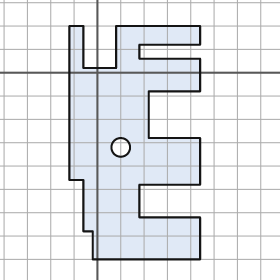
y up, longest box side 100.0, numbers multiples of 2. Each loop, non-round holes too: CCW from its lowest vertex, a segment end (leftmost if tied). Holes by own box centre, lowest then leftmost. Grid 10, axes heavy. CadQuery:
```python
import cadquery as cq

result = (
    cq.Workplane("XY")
    .moveTo(-2.0, -80.0)
    .lineTo(44.0, -80.0)
    .lineTo(44.0, -62.0)
    .lineTo(18.0, -62.0)
    .lineTo(18.0, -48.0)
    .lineTo(44.0, -48.0)
    .lineTo(44.0, -28.0)
    .lineTo(22.0, -28.0)
    .lineTo(22.0, -8.0)
    .lineTo(44.0, -8.0)
    .lineTo(44.0, 6.0)
    .lineTo(18.0, 6.0)
    .lineTo(18.0, 12.0)
    .lineTo(44.0, 12.0)
    .lineTo(44.0, 20.0)
    .lineTo(8.0, 20.0)
    .lineTo(8.0, 2.0)
    .lineTo(-6.0, 2.0)
    .lineTo(-6.0, 20.0)
    .lineTo(-12.0, 20.0)
    .lineTo(-12.0, -46.0)
    .lineTo(-6.0, -46.0)
    .lineTo(-6.0, -68.0)
    .lineTo(-2.0, -68.0)
    .close()
    .moveTo(10.0, -32.0)
    .circle(4.0)
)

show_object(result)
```